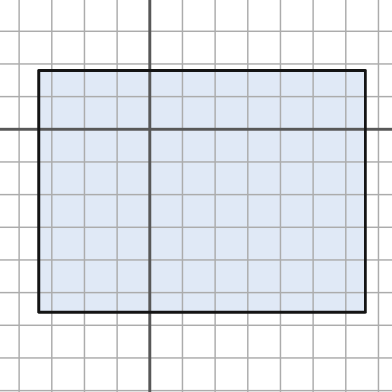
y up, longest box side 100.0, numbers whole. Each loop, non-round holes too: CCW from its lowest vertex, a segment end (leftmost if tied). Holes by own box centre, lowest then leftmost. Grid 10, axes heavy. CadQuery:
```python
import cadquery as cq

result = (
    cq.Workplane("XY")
    .moveTo(-34.0, -56.0)
    .lineTo(66.0, -56.0)
    .lineTo(66.0, 18.0)
    .lineTo(-34.0, 18.0)
    .close()
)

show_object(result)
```